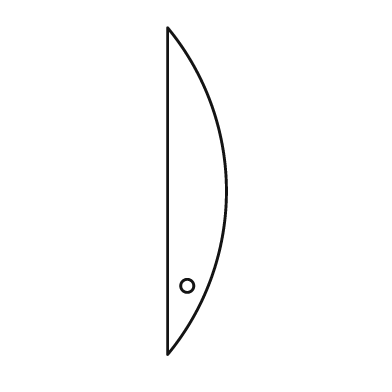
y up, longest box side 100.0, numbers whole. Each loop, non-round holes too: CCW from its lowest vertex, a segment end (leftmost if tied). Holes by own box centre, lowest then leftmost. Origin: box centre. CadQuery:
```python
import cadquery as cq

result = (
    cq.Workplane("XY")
    .moveTo(-9.0, -50.0)
    .threePointArc((9.0, 0.0), (-9.0, 50.0))
    .close()
    .moveTo(-3.0, -29.0)
    .circle(2.0)
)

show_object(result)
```